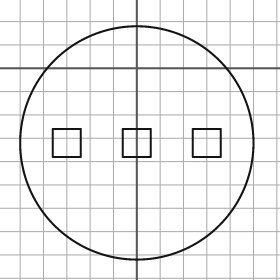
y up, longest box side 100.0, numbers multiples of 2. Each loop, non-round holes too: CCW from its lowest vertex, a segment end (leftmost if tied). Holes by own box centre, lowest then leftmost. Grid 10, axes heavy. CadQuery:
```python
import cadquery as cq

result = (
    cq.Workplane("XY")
    .moveTo(0.0, -32.0)
    .circle(50.0)
    .moveTo(-36.0, -38.0)
    .lineTo(-24.0, -38.0)
    .lineTo(-24.0, -26.0)
    .lineTo(-36.0, -26.0)
    .close()
    .moveTo(-6.0, -38.0)
    .lineTo(6.0, -38.0)
    .lineTo(6.0, -26.0)
    .lineTo(-6.0, -26.0)
    .close()
    .moveTo(24.0, -38.0)
    .lineTo(36.0, -38.0)
    .lineTo(36.0, -26.0)
    .lineTo(24.0, -26.0)
    .close()
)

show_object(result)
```